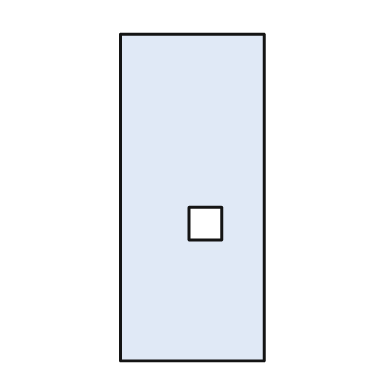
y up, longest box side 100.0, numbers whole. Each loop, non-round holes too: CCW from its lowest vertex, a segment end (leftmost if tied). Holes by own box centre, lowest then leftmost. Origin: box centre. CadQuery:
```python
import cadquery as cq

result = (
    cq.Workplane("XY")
    .moveTo(-22.0, -50.0)
    .lineTo(22.0, -50.0)
    .lineTo(22.0, 50.0)
    .lineTo(-22.0, 50.0)
    .close()
    .moveTo(-1.0, -13.0)
    .lineTo(9.0, -13.0)
    .lineTo(9.0, -3.0)
    .lineTo(-1.0, -3.0)
    .close()
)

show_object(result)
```